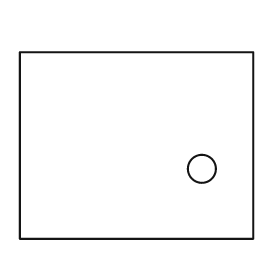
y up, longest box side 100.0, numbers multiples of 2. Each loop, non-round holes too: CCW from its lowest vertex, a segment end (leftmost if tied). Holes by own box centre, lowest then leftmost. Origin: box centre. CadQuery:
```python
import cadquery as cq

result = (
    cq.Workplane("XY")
    .moveTo(-50.0, -40.0)
    .lineTo(50.0, -40.0)
    .lineTo(50.0, 40.0)
    .lineTo(-50.0, 40.0)
    .close()
    .moveTo(28.0, -10.0)
    .circle(6.0)
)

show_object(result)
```